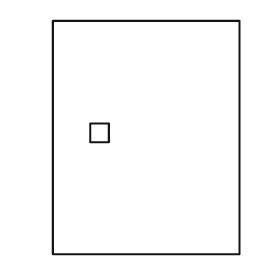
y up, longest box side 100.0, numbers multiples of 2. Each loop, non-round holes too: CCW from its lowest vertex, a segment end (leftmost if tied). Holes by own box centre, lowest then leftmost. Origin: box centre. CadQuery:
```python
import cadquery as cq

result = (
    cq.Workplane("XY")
    .moveTo(-40.0, -50.0)
    .lineTo(40.0, -50.0)
    .lineTo(40.0, 50.0)
    .lineTo(-40.0, 50.0)
    .close()
    .moveTo(-24.0, -2.0)
    .lineTo(-16.0, -2.0)
    .lineTo(-16.0, 6.0)
    .lineTo(-24.0, 6.0)
    .close()
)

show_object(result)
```